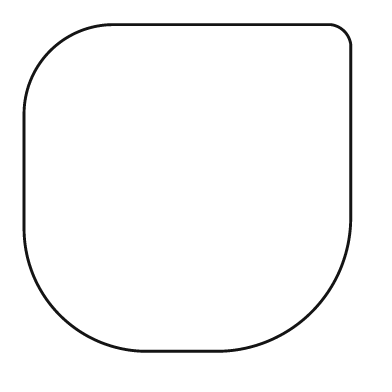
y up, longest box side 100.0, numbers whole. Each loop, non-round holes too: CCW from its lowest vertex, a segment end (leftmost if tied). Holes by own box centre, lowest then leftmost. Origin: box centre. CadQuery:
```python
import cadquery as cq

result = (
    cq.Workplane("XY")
    .moveTo(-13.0, -50.0)
    .lineTo(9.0, -50.0)
    .threePointArc((38.0, -38.0), (50.0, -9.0))
    .lineTo(50.0, 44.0)
    .threePointArc((48.0, 48.0), (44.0, 50.0))
    .lineTo(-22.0, 50.0)
    .threePointArc((-42.0, 42.0), (-50.0, 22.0))
    .lineTo(-50.0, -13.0)
    .threePointArc((-39.0, -39.0), (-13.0, -50.0))
    .close()
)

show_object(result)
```